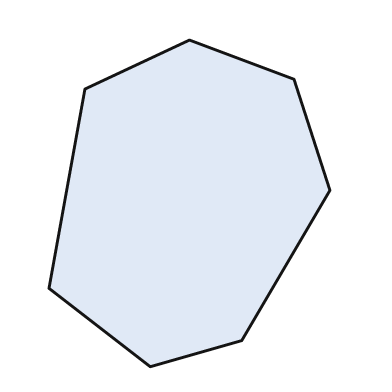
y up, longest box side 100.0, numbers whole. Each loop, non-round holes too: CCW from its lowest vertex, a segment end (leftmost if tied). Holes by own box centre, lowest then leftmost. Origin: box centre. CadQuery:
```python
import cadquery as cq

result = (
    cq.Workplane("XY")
    .moveTo(-12.0, -50.0)
    .lineTo(16.0, -42.0)
    .lineTo(43.0, 4.0)
    .lineTo(32.0, 38.0)
    .lineTo(0.0, 50.0)
    .lineTo(-32.0, 35.0)
    .lineTo(-43.0, -26.0)
    .close()
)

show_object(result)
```